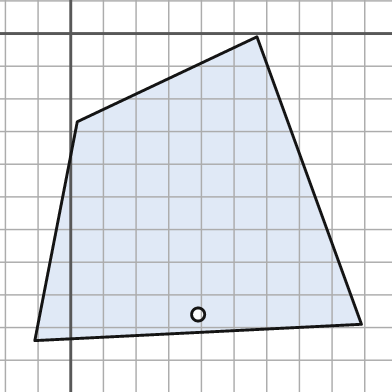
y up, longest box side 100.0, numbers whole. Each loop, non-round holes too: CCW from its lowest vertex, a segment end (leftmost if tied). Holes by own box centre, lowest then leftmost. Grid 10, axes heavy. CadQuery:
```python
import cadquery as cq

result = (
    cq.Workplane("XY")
    .moveTo(-11.0, -94.0)
    .lineTo(89.0, -89.0)
    .lineTo(57.0, -1.0)
    .lineTo(2.0, -27.0)
    .close()
    .moveTo(39.0, -86.0)
    .circle(2.0)
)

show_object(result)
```